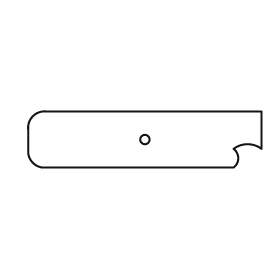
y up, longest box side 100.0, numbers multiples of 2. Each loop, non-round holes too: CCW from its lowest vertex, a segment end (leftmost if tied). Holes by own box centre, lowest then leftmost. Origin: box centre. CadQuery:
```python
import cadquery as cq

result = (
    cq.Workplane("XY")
    .moveTo(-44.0, -12.0)
    .lineTo(38.0, -12.0)
    .threePointArc((40.0, -8.0), (38.0, -4.0))
    .threePointArc((44.0, -2.0), (50.0, -4.0))
    .lineTo(50.0, 12.0)
    .lineTo(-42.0, 12.0)
    .threePointArc((-48.0, 10.0), (-50.0, 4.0))
    .lineTo(-50.0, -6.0)
    .threePointArc((-48.0, -10.0), (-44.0, -12.0))
    .close()
    .moveTo(0.0, 0.0)
    .circle(2.0)
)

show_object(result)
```